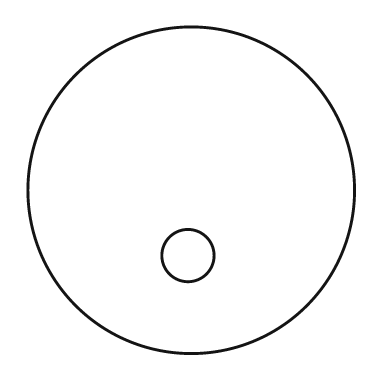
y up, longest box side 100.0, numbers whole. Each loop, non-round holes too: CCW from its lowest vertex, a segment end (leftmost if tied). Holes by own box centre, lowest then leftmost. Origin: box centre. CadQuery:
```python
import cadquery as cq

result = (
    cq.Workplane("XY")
    .moveTo(0.0, 0.0)
    .circle(50.0)
    .moveTo(-1.0, -20.0)
    .circle(8.0)
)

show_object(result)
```